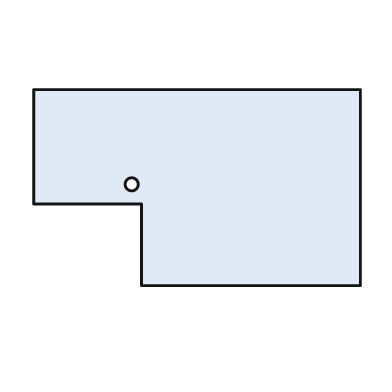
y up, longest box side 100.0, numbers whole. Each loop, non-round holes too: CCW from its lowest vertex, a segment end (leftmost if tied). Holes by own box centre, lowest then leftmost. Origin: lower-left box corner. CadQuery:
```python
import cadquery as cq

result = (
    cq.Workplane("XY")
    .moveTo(33.0, 0.0)
    .lineTo(100.0, 0.0)
    .lineTo(100.0, 60.0)
    .lineTo(0.0, 60.0)
    .lineTo(0.0, 25.0)
    .lineTo(33.0, 25.0)
    .close()
    .moveTo(30.0, 31.0)
    .circle(2.0)
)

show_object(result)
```